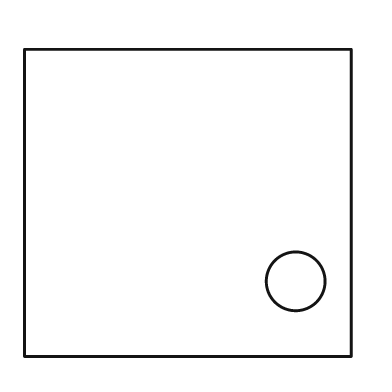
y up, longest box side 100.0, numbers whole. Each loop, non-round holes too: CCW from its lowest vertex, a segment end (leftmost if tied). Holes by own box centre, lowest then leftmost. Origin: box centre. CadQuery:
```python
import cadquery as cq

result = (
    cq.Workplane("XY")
    .moveTo(-50.0, -47.0)
    .lineTo(50.0, -47.0)
    .lineTo(50.0, 47.0)
    .lineTo(-50.0, 47.0)
    .close()
    .moveTo(33.0, -24.0)
    .circle(9.0)
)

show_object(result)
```